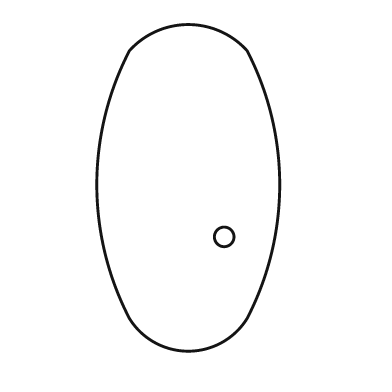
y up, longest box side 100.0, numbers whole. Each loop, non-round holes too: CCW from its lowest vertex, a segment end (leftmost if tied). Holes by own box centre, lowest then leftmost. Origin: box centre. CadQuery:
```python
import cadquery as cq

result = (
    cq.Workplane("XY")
    .moveTo(-18.0, -40.0)
    .threePointArc((0.0, -50.0), (18.0, -40.0))
    .threePointArc((28.0, 1.0), (18.0, 42.0))
    .threePointArc((0.0, 50.0), (-18.0, 42.0))
    .threePointArc((-28.0, 1.0), (-18.0, -40.0))
    .close()
    .moveTo(11.0, -15.0)
    .circle(3.0)
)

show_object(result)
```